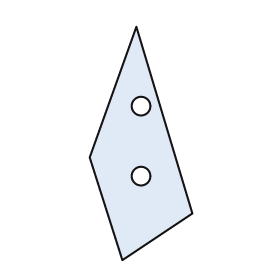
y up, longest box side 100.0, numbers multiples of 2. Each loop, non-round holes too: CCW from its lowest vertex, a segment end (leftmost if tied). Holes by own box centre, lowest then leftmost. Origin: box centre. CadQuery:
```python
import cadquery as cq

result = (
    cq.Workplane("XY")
    .moveTo(-8.0, -50.0)
    .lineTo(22.0, -30.0)
    .lineTo(-2.0, 50.0)
    .lineTo(-22.0, -6.0)
    .close()
    .moveTo(0.0, -14.0)
    .circle(4.0)
    .moveTo(0.0, 16.0)
    .circle(4.0)
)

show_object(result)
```